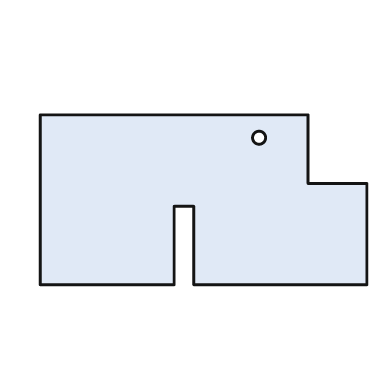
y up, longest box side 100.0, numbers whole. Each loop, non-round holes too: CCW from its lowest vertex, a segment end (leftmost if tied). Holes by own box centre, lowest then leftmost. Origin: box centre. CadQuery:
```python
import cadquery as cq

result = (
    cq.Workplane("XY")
    .moveTo(-50.0, -26.0)
    .lineTo(-9.0, -26.0)
    .lineTo(-9.0, -2.0)
    .lineTo(-3.0, -2.0)
    .lineTo(-3.0, -26.0)
    .lineTo(50.0, -26.0)
    .lineTo(50.0, 5.0)
    .lineTo(32.0, 5.0)
    .lineTo(32.0, 26.0)
    .lineTo(-50.0, 26.0)
    .close()
    .moveTo(17.0, 19.0)
    .circle(2.0)
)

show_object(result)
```